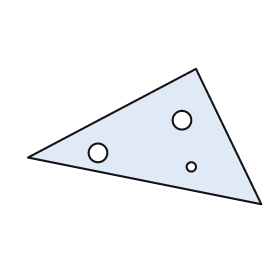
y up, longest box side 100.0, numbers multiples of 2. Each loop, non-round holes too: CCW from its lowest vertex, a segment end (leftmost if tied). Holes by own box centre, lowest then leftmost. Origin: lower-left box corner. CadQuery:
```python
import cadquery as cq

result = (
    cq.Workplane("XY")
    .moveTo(100.0, 0.0)
    .lineTo(72.0, 58.0)
    .lineTo(0.0, 20.0)
    .close()
    .moveTo(70.0, 16.0)
    .circle(2.0)
    .moveTo(30.0, 22.0)
    .circle(4.0)
    .moveTo(66.0, 36.0)
    .circle(4.0)
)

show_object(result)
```